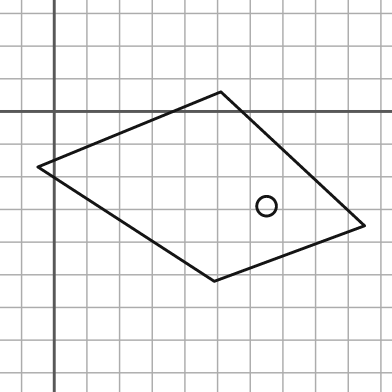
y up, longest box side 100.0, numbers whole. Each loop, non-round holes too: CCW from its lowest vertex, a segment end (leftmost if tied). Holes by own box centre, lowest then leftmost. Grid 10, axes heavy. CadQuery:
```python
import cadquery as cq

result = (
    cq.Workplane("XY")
    .moveTo(49.0, -52.0)
    .lineTo(95.0, -35.0)
    .lineTo(51.0, 6.0)
    .lineTo(-5.0, -17.0)
    .close()
    .moveTo(65.0, -29.0)
    .circle(3.0)
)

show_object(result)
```